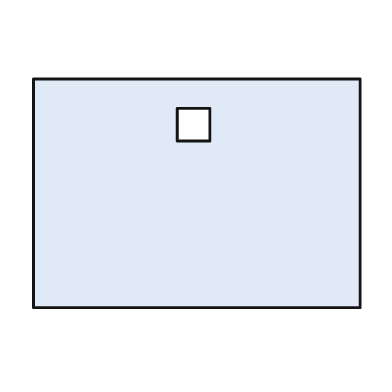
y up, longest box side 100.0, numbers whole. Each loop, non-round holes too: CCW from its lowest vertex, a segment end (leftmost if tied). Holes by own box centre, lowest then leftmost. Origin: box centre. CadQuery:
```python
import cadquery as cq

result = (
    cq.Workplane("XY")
    .moveTo(-50.0, -35.0)
    .lineTo(50.0, -35.0)
    .lineTo(50.0, 35.0)
    .lineTo(-50.0, 35.0)
    .close()
    .moveTo(-6.0, 16.0)
    .lineTo(4.0, 16.0)
    .lineTo(4.0, 26.0)
    .lineTo(-6.0, 26.0)
    .close()
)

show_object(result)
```